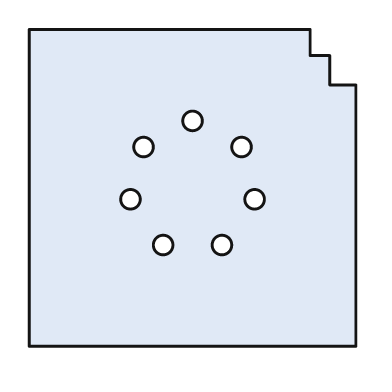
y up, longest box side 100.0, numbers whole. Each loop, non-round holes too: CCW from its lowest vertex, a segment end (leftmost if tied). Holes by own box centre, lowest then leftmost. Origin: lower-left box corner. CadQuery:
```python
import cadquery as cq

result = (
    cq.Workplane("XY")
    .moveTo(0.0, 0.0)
    .lineTo(100.0, 0.0)
    .lineTo(100.0, 80.0)
    .lineTo(92.0, 80.0)
    .lineTo(92.0, 89.0)
    .lineTo(86.0, 89.0)
    .lineTo(86.0, 97.0)
    .lineTo(0.0, 97.0)
    .close()
    .moveTo(41.0, 31.0)
    .circle(3.0)
    .moveTo(59.0, 31.0)
    .circle(3.0)
    .moveTo(31.0, 45.0)
    .circle(3.0)
    .moveTo(69.0, 45.0)
    .circle(3.0)
    .moveTo(35.0, 61.0)
    .circle(3.0)
    .moveTo(65.0, 61.0)
    .circle(3.0)
    .moveTo(50.0, 69.0)
    .circle(3.0)
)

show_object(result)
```